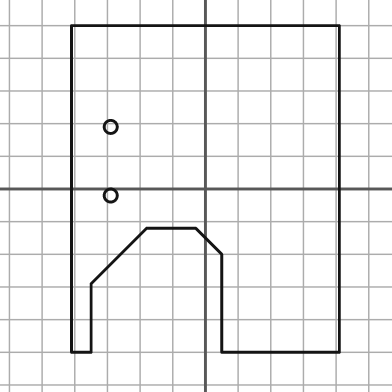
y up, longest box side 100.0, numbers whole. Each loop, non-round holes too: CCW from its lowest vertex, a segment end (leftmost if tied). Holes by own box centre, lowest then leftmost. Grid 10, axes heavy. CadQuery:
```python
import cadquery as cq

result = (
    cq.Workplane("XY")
    .moveTo(-41.0, -50.0)
    .lineTo(-35.0, -50.0)
    .lineTo(-35.0, -29.0)
    .lineTo(-18.0, -12.0)
    .lineTo(-3.0, -12.0)
    .lineTo(5.0, -20.0)
    .lineTo(5.0, -50.0)
    .lineTo(41.0, -50.0)
    .lineTo(41.0, 50.0)
    .lineTo(-41.0, 50.0)
    .close()
    .moveTo(-29.0, -2.0)
    .circle(2.0)
    .moveTo(-29.0, 19.0)
    .circle(2.0)
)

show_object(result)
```